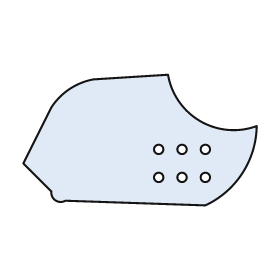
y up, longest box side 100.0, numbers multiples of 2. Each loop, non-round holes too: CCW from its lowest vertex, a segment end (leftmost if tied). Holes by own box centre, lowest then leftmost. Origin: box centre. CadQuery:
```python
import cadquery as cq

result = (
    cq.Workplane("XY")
    .moveTo(28.0, -28.0)
    .threePointArc((44.0, -14.0), (50.0, 6.0))
    .threePointArc((26.0, 8.0), (12.0, 28.0))
    .lineTo(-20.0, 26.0)
    .threePointArc((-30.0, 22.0), (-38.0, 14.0))
    .lineTo(-50.0, -10.0)
    .lineTo(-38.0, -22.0)
    .threePointArc((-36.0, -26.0), (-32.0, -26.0))
    .close()
    .moveTo(8.0, -16.0)
    .circle(2.0)
    .moveTo(18.0, -16.0)
    .circle(2.0)
    .moveTo(28.0, -16.0)
    .circle(2.0)
    .moveTo(8.0, -4.0)
    .circle(2.0)
    .moveTo(18.0, -4.0)
    .circle(2.0)
    .moveTo(28.0, -4.0)
    .circle(2.0)
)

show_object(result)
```